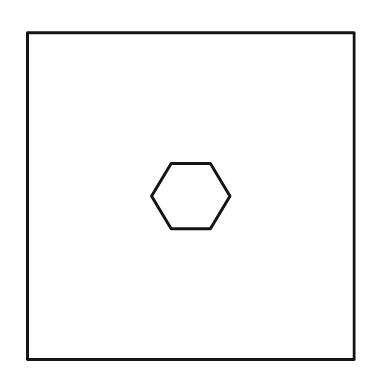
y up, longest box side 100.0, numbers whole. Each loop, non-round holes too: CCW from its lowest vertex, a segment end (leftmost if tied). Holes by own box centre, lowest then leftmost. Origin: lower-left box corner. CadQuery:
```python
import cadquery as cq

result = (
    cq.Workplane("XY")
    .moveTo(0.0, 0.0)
    .lineTo(100.0, 0.0)
    .lineTo(100.0, 100.0)
    .lineTo(0.0, 100.0)
    .close()
    .moveTo(44.0, 40.0)
    .lineTo(56.0, 40.0)
    .lineTo(62.0, 50.0)
    .lineTo(56.0, 60.0)
    .lineTo(44.0, 60.0)
    .lineTo(38.0, 50.0)
    .close()
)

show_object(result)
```